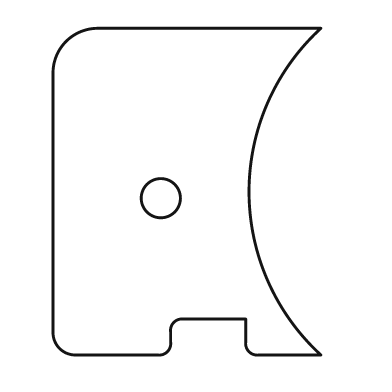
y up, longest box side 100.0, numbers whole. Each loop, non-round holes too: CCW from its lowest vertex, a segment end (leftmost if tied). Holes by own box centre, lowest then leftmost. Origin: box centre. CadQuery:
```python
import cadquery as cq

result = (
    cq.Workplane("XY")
    .moveTo(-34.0, -50.0)
    .lineTo(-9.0, -50.0)
    .threePointArc((-6.0, -49.0), (-5.0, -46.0))
    .lineTo(-5.0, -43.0)
    .threePointArc((-4.0, -40.0), (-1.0, -39.0))
    .lineTo(18.0, -39.0)
    .lineTo(18.0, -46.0)
    .threePointArc((19.0, -49.0), (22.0, -50.0))
    .lineTo(41.0, -50.0)
    .threePointArc((19.0, 0.0), (41.0, 50.0))
    .lineTo(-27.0, 50.0)
    .threePointArc((-37.0, 46.0), (-41.0, 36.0))
    .lineTo(-41.0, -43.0)
    .threePointArc((-39.0, -48.0), (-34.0, -50.0))
    .close()
    .moveTo(-8.0, -2.0)
    .circle(6.0)
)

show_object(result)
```